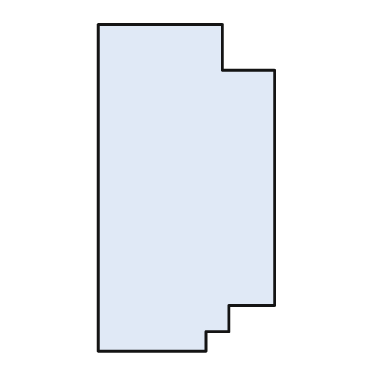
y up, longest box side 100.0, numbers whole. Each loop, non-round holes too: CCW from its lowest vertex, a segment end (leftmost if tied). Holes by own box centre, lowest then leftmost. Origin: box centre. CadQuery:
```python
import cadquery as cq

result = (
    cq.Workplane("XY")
    .moveTo(-27.0, -50.0)
    .lineTo(6.0, -50.0)
    .lineTo(6.0, -44.0)
    .lineTo(13.0, -44.0)
    .lineTo(13.0, -36.0)
    .lineTo(27.0, -36.0)
    .lineTo(27.0, 36.0)
    .lineTo(11.0, 36.0)
    .lineTo(11.0, 50.0)
    .lineTo(-27.0, 50.0)
    .close()
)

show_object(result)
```